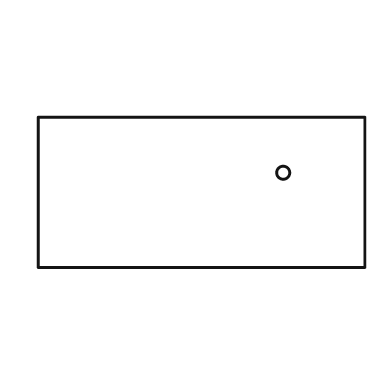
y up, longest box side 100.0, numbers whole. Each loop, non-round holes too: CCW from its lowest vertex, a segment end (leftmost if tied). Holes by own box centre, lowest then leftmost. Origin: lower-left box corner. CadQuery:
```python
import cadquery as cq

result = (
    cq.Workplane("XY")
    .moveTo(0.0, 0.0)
    .lineTo(100.0, 0.0)
    .lineTo(100.0, 46.0)
    .lineTo(0.0, 46.0)
    .close()
    .moveTo(75.0, 29.0)
    .circle(2.0)
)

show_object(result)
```